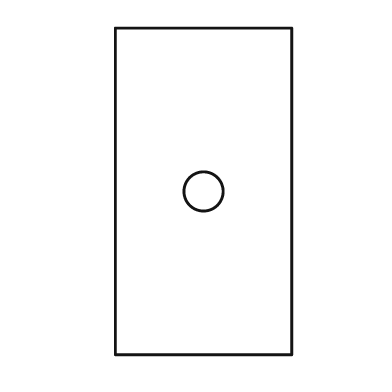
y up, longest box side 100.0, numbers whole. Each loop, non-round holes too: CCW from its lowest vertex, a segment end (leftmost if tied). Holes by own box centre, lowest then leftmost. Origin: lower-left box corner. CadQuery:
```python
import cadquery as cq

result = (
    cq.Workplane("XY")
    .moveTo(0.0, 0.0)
    .lineTo(54.0, 0.0)
    .lineTo(54.0, 100.0)
    .lineTo(0.0, 100.0)
    .close()
    .moveTo(27.0, 50.0)
    .circle(6.0)
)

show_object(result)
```